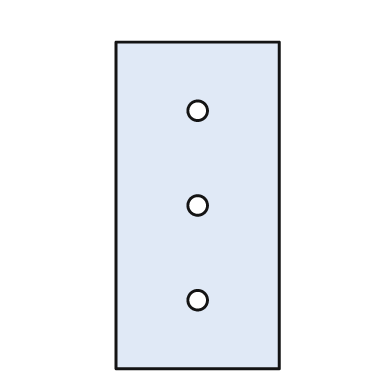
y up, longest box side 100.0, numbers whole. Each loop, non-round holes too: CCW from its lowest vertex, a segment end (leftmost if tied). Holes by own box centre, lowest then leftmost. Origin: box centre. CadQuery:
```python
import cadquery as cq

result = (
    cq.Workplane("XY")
    .moveTo(-25.0, -50.0)
    .lineTo(25.0, -50.0)
    .lineTo(25.0, 50.0)
    .lineTo(-25.0, 50.0)
    .close()
    .moveTo(0.0, -29.0)
    .circle(3.0)
    .moveTo(0.0, 0.0)
    .circle(3.0)
    .moveTo(0.0, 29.0)
    .circle(3.0)
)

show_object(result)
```